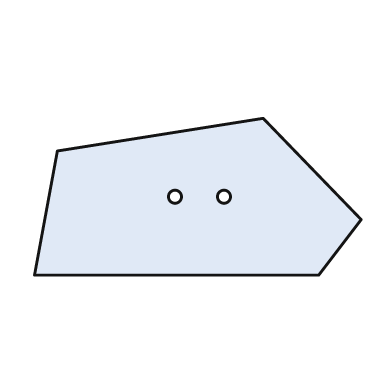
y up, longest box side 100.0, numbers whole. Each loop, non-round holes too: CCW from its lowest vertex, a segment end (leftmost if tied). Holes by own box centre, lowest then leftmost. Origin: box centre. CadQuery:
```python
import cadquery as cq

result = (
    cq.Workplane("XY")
    .moveTo(-50.0, -24.0)
    .lineTo(37.0, -24.0)
    .lineTo(50.0, -7.0)
    .lineTo(20.0, 24.0)
    .lineTo(-43.0, 14.0)
    .close()
    .moveTo(-7.0, 0.0)
    .circle(2.0)
    .moveTo(8.0, 0.0)
    .circle(2.0)
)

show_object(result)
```